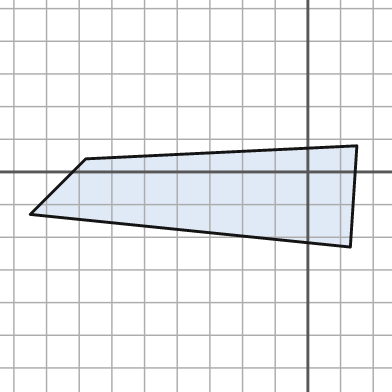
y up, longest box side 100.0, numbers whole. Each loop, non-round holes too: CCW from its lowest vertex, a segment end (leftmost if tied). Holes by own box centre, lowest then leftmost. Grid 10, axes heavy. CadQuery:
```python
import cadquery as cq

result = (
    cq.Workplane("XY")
    .moveTo(13.0, -23.0)
    .lineTo(15.0, 8.0)
    .lineTo(-68.0, 4.0)
    .lineTo(-85.0, -13.0)
    .close()
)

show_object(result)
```